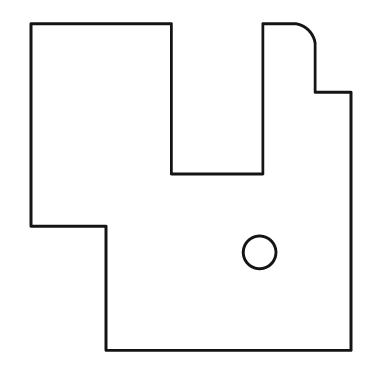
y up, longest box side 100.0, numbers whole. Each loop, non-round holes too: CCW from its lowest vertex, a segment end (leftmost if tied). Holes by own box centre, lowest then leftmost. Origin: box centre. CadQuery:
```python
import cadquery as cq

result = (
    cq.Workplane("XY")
    .moveTo(-26.0, -50.0)
    .lineTo(49.0, -50.0)
    .lineTo(49.0, 29.0)
    .lineTo(38.0, 29.0)
    .lineTo(38.0, 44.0)
    .threePointArc((36.0, 48.0), (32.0, 50.0))
    .lineTo(22.0, 50.0)
    .lineTo(22.0, 4.0)
    .lineTo(-6.0, 4.0)
    .lineTo(-6.0, 50.0)
    .lineTo(-49.0, 50.0)
    .lineTo(-49.0, -12.0)
    .lineTo(-26.0, -12.0)
    .close()
    .moveTo(21.0, -20.0)
    .circle(5.0)
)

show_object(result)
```